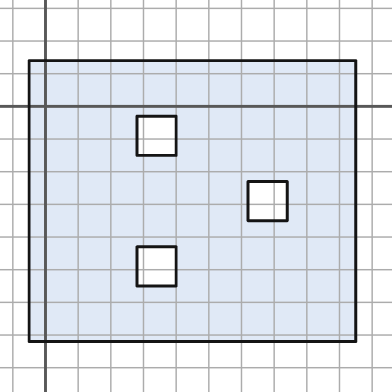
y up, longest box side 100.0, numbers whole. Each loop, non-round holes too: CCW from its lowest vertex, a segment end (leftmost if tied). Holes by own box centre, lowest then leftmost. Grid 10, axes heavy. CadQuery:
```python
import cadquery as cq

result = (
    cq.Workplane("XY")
    .moveTo(-5.0, -72.0)
    .lineTo(95.0, -72.0)
    .lineTo(95.0, 14.0)
    .lineTo(-5.0, 14.0)
    .close()
    .moveTo(28.0, -55.0)
    .lineTo(40.0, -55.0)
    .lineTo(40.0, -43.0)
    .lineTo(28.0, -43.0)
    .close()
    .moveTo(62.0, -35.0)
    .lineTo(74.0, -35.0)
    .lineTo(74.0, -23.0)
    .lineTo(62.0, -23.0)
    .close()
    .moveTo(28.0, -15.0)
    .lineTo(40.0, -15.0)
    .lineTo(40.0, -3.0)
    .lineTo(28.0, -3.0)
    .close()
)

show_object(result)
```